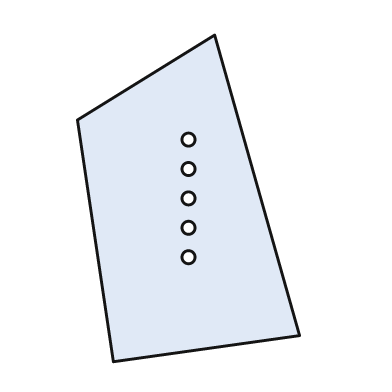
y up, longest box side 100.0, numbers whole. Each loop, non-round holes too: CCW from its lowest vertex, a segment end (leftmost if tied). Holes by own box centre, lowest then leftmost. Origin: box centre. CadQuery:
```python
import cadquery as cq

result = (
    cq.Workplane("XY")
    .moveTo(-23.0, -50.0)
    .lineTo(34.0, -42.0)
    .lineTo(8.0, 50.0)
    .lineTo(-34.0, 24.0)
    .close()
    .moveTo(0.0, -18.0)
    .circle(2.0)
    .moveTo(0.0, -9.0)
    .circle(2.0)
    .moveTo(0.0, 0.0)
    .circle(2.0)
    .moveTo(0.0, 9.0)
    .circle(2.0)
    .moveTo(0.0, 18.0)
    .circle(2.0)
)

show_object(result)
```